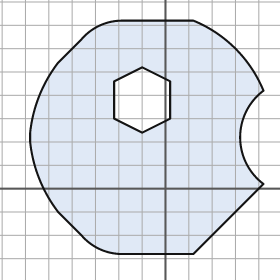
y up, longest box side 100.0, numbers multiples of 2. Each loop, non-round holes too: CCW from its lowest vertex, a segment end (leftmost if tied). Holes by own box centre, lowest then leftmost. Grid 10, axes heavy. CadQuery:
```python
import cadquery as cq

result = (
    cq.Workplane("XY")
    .moveTo(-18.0, -28.0)
    .lineTo(12.0, -28.0)
    .lineTo(42.0, 2.0)
    .threePointArc((32.0, 22.0), (42.0, 42.0))
    .threePointArc((30.0, 60.0), (12.0, 72.0))
    .lineTo(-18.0, 72.0)
    .threePointArc((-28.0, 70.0), (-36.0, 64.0))
    .lineTo(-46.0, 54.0)
    .threePointArc((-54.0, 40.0), (-58.0, 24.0))
    .lineTo(-58.0, 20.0)
    .threePointArc((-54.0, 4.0), (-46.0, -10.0))
    .lineTo(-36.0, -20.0)
    .threePointArc((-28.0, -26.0), (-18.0, -28.0))
    .close()
    .moveTo(-10.0, 24.0)
    .lineTo(2.0, 30.0)
    .lineTo(2.0, 46.0)
    .lineTo(-10.0, 52.0)
    .lineTo(-22.0, 46.0)
    .lineTo(-22.0, 30.0)
    .close()
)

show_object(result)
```